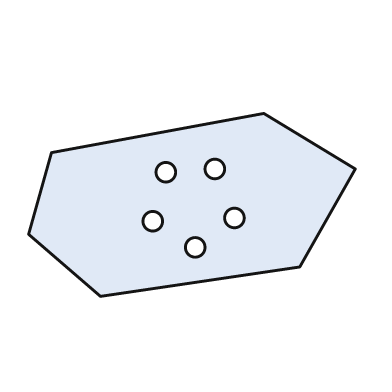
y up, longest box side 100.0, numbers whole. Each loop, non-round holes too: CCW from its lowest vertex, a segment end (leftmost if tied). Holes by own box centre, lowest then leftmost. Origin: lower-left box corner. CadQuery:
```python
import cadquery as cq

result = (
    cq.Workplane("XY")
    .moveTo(22.0, 0.0)
    .lineTo(83.0, 9.0)
    .lineTo(100.0, 39.0)
    .lineTo(72.0, 56.0)
    .lineTo(7.0, 44.0)
    .lineTo(0.0, 19.0)
    .close()
    .moveTo(51.0, 15.0)
    .circle(3.0)
    .moveTo(38.0, 23.0)
    .circle(3.0)
    .moveTo(63.0, 24.0)
    .circle(3.0)
    .moveTo(42.0, 38.0)
    .circle(3.0)
    .moveTo(57.0, 39.0)
    .circle(3.0)
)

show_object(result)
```